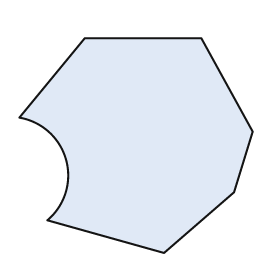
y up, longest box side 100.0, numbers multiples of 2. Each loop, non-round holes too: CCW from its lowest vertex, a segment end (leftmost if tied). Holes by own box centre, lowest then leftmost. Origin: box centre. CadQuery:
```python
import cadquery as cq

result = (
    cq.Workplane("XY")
    .moveTo(12.0, -46.0)
    .lineTo(42.0, -20.0)
    .lineTo(50.0, 6.0)
    .lineTo(28.0, 46.0)
    .lineTo(-22.0, 46.0)
    .lineTo(-50.0, 12.0)
    .threePointArc((-30.0, -6.0), (-38.0, -32.0))
    .close()
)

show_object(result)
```